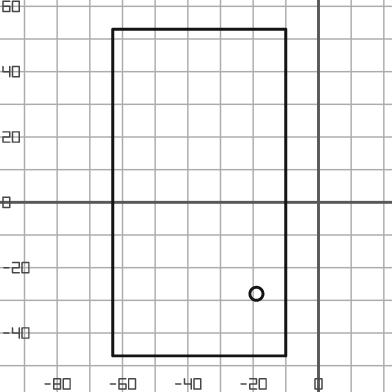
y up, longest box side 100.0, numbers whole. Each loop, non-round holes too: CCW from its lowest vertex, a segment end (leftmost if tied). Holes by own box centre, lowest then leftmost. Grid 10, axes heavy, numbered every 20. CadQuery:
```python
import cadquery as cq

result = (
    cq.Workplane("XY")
    .moveTo(-63.0, -47.0)
    .lineTo(-10.0, -47.0)
    .lineTo(-10.0, 53.0)
    .lineTo(-63.0, 53.0)
    .close()
    .moveTo(-19.0, -28.0)
    .circle(2.0)
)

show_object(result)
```